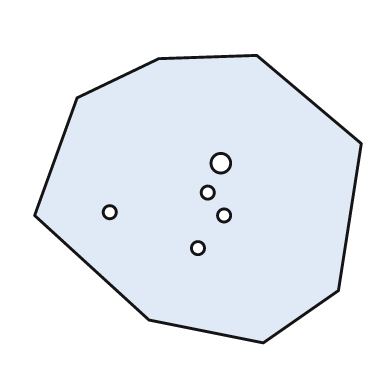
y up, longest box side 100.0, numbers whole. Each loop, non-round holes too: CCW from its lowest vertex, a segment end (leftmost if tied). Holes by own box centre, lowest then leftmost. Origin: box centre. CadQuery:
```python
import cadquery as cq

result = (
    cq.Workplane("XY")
    .moveTo(20.0, -44.0)
    .lineTo(43.0, -28.0)
    .lineTo(50.0, 17.0)
    .lineTo(18.0, 44.0)
    .lineTo(-12.0, 43.0)
    .lineTo(-37.0, 31.0)
    .lineTo(-50.0, -5.0)
    .lineTo(-15.0, -37.0)
    .close()
    .moveTo(0.0, -15.0)
    .circle(2.0)
    .moveTo(8.0, -5.0)
    .circle(2.0)
    .moveTo(-27.0, -4.0)
    .circle(2.0)
    .moveTo(3.0, 2.0)
    .circle(2.0)
    .moveTo(7.0, 11.0)
    .circle(3.0)
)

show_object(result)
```